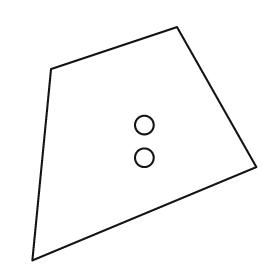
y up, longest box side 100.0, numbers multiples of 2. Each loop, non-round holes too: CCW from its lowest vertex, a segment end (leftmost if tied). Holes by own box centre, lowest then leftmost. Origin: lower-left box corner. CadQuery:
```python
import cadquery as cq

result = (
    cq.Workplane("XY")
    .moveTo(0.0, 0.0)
    .lineTo(96.0, 40.0)
    .lineTo(62.0, 100.0)
    .lineTo(8.0, 82.0)
    .close()
    .moveTo(48.0, 44.0)
    .circle(4.0)
    .moveTo(48.0, 58.0)
    .circle(4.0)
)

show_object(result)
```